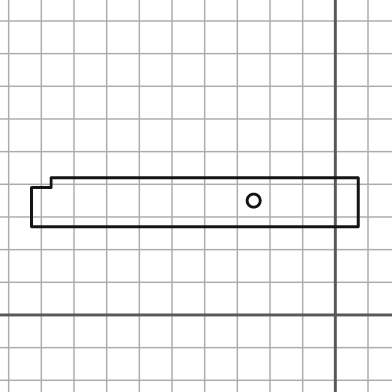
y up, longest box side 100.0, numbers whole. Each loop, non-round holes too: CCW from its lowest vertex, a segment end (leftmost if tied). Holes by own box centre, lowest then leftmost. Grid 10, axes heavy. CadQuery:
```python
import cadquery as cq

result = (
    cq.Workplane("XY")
    .moveTo(-93.0, 27.0)
    .lineTo(7.0, 27.0)
    .lineTo(7.0, 42.0)
    .lineTo(-87.0, 42.0)
    .lineTo(-87.0, 39.0)
    .lineTo(-93.0, 39.0)
    .close()
    .moveTo(-25.0, 35.0)
    .circle(2.0)
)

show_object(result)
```